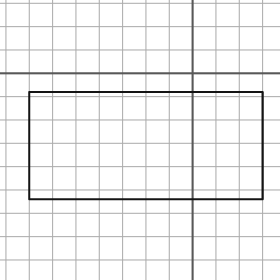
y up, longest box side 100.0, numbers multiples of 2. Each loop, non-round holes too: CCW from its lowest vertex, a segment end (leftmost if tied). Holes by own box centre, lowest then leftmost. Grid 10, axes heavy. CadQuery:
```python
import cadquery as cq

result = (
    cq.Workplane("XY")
    .moveTo(-70.0, -54.0)
    .lineTo(30.0, -54.0)
    .lineTo(30.0, -8.0)
    .lineTo(-70.0, -8.0)
    .close()
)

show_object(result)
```